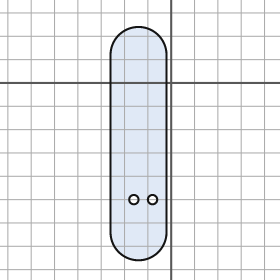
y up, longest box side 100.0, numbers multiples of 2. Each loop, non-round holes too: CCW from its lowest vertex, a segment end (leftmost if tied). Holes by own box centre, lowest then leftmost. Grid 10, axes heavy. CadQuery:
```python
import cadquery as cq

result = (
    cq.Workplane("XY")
    .moveTo(-26.0, -64.0)
    .threePointArc((-14.0, -76.0), (-2.0, -64.0))
    .lineTo(-2.0, 12.0)
    .threePointArc((-14.0, 24.0), (-26.0, 12.0))
    .close()
    .moveTo(-16.0, -50.0)
    .circle(2.0)
    .moveTo(-8.0, -50.0)
    .circle(2.0)
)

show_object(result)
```